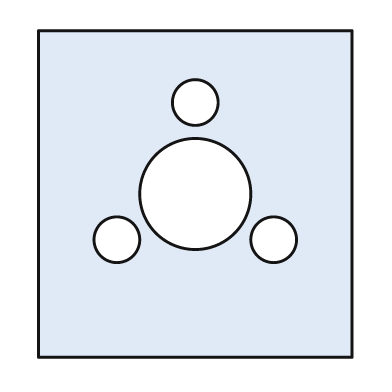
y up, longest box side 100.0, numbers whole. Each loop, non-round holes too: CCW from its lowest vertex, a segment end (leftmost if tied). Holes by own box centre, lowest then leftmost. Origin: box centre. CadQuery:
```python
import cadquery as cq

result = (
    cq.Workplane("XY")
    .moveTo(-48.0, -50.0)
    .lineTo(48.0, -50.0)
    .lineTo(48.0, 50.0)
    .lineTo(-48.0, 50.0)
    .close()
    .moveTo(-24.0, -14.0)
    .circle(7.0)
    .moveTo(24.0, -14.0)
    .circle(7.0)
    .moveTo(0.0, 0.0)
    .circle(17.0)
    .moveTo(0.0, 28.0)
    .circle(7.0)
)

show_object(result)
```